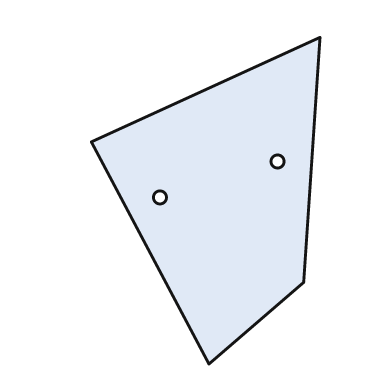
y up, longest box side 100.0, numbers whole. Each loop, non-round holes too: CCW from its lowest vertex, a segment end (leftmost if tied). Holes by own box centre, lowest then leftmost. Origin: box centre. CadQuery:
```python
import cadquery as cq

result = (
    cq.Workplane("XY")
    .moveTo(1.0, -50.0)
    .lineTo(30.0, -25.0)
    .lineTo(35.0, 50.0)
    .lineTo(-35.0, 18.0)
    .close()
    .moveTo(-14.0, 1.0)
    .circle(2.0)
    .moveTo(22.0, 12.0)
    .circle(2.0)
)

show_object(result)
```